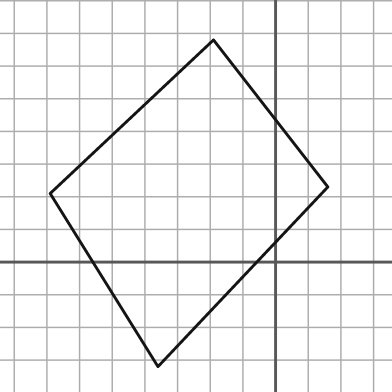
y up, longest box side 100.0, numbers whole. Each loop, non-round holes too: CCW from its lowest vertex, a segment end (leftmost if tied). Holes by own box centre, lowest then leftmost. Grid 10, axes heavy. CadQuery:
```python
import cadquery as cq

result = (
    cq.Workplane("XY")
    .moveTo(-36.0, -32.0)
    .lineTo(16.0, 23.0)
    .lineTo(-19.0, 68.0)
    .lineTo(-69.0, 21.0)
    .close()
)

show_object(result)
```